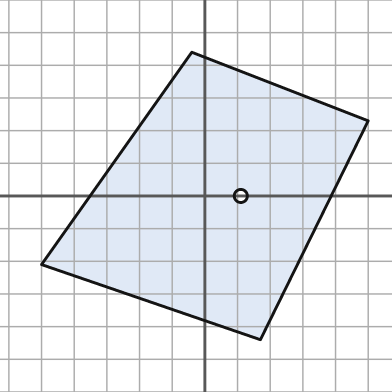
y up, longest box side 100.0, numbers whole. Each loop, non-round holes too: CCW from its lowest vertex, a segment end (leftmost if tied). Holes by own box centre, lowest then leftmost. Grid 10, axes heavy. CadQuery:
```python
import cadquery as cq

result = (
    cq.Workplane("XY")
    .moveTo(17.0, -44.0)
    .lineTo(50.0, 23.0)
    .lineTo(-4.0, 44.0)
    .lineTo(-50.0, -21.0)
    .close()
    .moveTo(11.0, 0.0)
    .circle(2.0)
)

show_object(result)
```